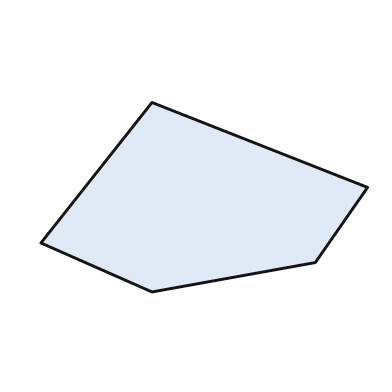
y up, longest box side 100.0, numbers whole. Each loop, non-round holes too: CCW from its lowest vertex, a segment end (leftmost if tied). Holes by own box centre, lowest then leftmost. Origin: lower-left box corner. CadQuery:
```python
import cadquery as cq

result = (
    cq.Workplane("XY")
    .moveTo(34.0, 0.0)
    .lineTo(84.0, 9.0)
    .lineTo(100.0, 32.0)
    .lineTo(34.0, 58.0)
    .lineTo(0.0, 15.0)
    .close()
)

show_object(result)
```